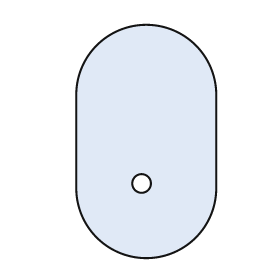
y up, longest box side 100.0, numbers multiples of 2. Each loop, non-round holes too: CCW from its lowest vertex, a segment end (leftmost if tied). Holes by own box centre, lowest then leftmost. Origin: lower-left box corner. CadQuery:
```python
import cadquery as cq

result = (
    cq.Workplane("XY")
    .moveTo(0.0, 30.0)
    .threePointArc((30.0, 0.0), (60.0, 30.0))
    .lineTo(60.0, 70.0)
    .threePointArc((30.0, 100.0), (0.0, 70.0))
    .close()
    .moveTo(28.0, 32.0)
    .circle(4.0)
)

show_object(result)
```